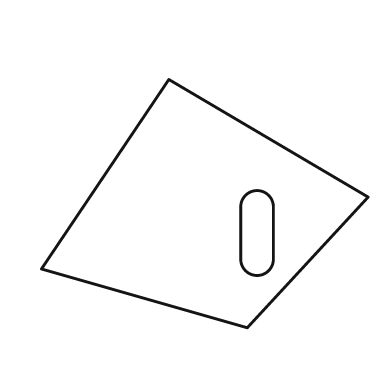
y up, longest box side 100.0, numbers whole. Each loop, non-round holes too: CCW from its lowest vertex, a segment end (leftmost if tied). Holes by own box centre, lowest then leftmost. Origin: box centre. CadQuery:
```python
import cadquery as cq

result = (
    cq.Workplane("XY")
    .moveTo(13.0, -38.0)
    .lineTo(50.0, 2.0)
    .lineTo(-11.0, 38.0)
    .lineTo(-50.0, -20.0)
    .close()
    .moveTo(11.0, -17.0)
    .threePointArc((16.0, -22.0), (21.0, -17.0))
    .lineTo(21.0, -1.0)
    .threePointArc((16.0, 4.0), (11.0, -1.0))
    .close()
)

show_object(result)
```